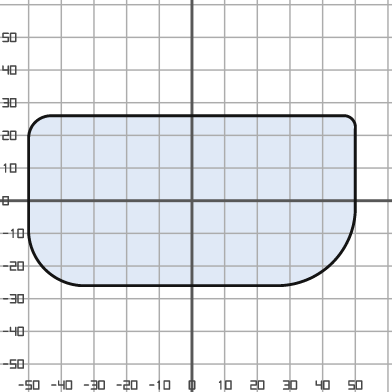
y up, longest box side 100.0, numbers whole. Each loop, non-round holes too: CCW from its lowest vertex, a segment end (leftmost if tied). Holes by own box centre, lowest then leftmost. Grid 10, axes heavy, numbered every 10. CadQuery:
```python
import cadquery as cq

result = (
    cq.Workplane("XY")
    .moveTo(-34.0, -26.0)
    .lineTo(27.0, -26.0)
    .threePointArc((43.0, -19.0), (50.0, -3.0))
    .lineTo(50.0, 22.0)
    .threePointArc((49.0, 25.0), (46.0, 26.0))
    .lineTo(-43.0, 26.0)
    .threePointArc((-48.0, 24.0), (-50.0, 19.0))
    .lineTo(-50.0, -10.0)
    .threePointArc((-45.0, -21.0), (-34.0, -26.0))
    .close()
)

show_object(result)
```